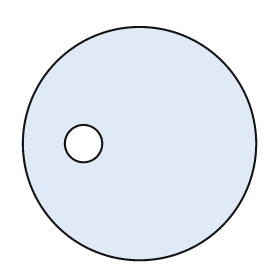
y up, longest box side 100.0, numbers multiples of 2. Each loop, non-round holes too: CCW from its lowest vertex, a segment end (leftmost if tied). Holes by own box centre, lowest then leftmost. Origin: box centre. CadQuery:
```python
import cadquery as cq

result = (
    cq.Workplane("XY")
    .moveTo(0.0, 0.0)
    .circle(50.0)
    .moveTo(-24.0, 0.0)
    .circle(8.0)
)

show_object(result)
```